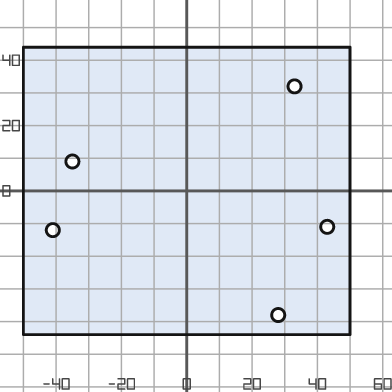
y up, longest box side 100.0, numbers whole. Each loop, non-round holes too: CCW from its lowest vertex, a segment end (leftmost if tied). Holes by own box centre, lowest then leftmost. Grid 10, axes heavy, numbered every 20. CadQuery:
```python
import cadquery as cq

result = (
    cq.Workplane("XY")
    .moveTo(-50.0, -44.0)
    .lineTo(50.0, -44.0)
    .lineTo(50.0, 44.0)
    .lineTo(-50.0, 44.0)
    .close()
    .moveTo(28.0, -38.0)
    .circle(2.0)
    .moveTo(-41.0, -12.0)
    .circle(2.0)
    .moveTo(43.0, -11.0)
    .circle(2.0)
    .moveTo(-35.0, 9.0)
    .circle(2.0)
    .moveTo(33.0, 32.0)
    .circle(2.0)
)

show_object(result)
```